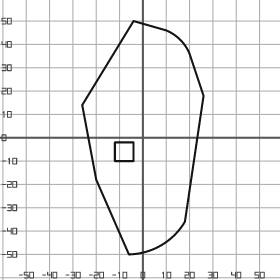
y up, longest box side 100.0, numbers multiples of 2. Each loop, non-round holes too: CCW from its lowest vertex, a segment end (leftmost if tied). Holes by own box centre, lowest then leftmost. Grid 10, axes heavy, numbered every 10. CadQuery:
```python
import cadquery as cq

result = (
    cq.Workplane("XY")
    .moveTo(-6.0, -50.0)
    .threePointArc((8.0, -46.0), (18.0, -36.0))
    .lineTo(26.0, 18.0)
    .lineTo(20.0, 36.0)
    .threePointArc((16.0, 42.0), (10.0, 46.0))
    .lineTo(-4.0, 50.0)
    .lineTo(-26.0, 14.0)
    .lineTo(-20.0, -18.0)
    .close()
    .moveTo(-12.0, -10.0)
    .lineTo(-4.0, -10.0)
    .lineTo(-4.0, -2.0)
    .lineTo(-12.0, -2.0)
    .close()
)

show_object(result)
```